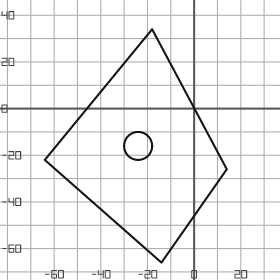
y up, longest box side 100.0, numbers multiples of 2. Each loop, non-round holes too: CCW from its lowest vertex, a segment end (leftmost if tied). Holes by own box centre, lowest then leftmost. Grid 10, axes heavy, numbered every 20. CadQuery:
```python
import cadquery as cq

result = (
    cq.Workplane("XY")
    .moveTo(-14.0, -66.0)
    .lineTo(14.0, -26.0)
    .lineTo(-18.0, 34.0)
    .lineTo(-64.0, -22.0)
    .close()
    .moveTo(-24.0, -16.0)
    .circle(6.0)
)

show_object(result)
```